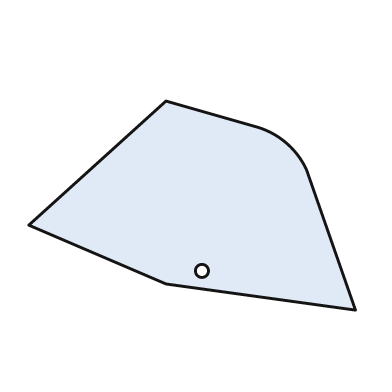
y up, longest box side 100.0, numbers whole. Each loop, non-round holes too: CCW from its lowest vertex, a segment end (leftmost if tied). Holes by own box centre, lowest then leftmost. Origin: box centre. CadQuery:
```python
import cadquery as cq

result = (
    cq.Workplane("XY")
    .moveTo(50.0, -32.0)
    .lineTo(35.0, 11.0)
    .threePointArc((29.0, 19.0), (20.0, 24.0))
    .lineTo(-8.0, 32.0)
    .lineTo(-50.0, -6.0)
    .lineTo(-8.0, -24.0)
    .close()
    .moveTo(3.0, -20.0)
    .circle(2.0)
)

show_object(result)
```